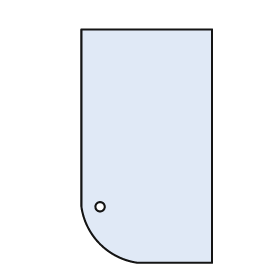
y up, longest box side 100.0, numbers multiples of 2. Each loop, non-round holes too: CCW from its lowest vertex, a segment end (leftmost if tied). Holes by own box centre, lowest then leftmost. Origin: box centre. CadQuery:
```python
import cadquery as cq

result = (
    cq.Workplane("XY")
    .moveTo(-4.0, -50.0)
    .lineTo(28.0, -50.0)
    .lineTo(28.0, 50.0)
    .lineTo(-28.0, 50.0)
    .lineTo(-28.0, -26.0)
    .threePointArc((-20.0, -42.0), (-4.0, -50.0))
    .close()
    .moveTo(-20.0, -26.0)
    .circle(2.0)
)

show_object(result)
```